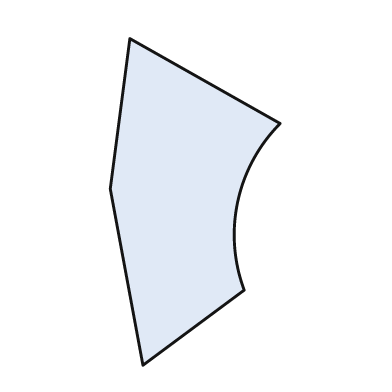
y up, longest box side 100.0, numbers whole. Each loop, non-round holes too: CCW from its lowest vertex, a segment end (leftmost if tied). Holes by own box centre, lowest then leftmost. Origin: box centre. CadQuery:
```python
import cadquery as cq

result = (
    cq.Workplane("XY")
    .moveTo(-16.0, -50.0)
    .lineTo(15.0, -27.0)
    .threePointArc((13.0, 0.0), (26.0, 24.0))
    .lineTo(-20.0, 50.0)
    .lineTo(-26.0, 4.0)
    .close()
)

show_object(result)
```